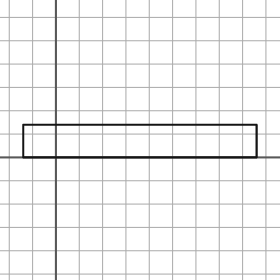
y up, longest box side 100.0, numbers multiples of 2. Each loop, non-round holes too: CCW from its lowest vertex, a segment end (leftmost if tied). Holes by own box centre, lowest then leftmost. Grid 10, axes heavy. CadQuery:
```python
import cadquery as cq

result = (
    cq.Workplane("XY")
    .moveTo(-14.0, 0.0)
    .lineTo(86.0, 0.0)
    .lineTo(86.0, 14.0)
    .lineTo(-14.0, 14.0)
    .close()
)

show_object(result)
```